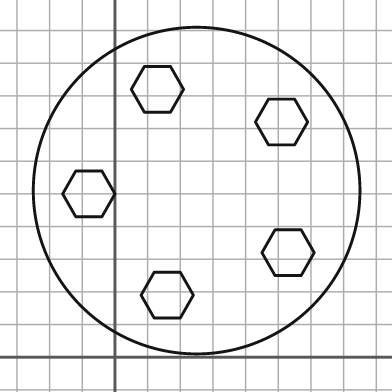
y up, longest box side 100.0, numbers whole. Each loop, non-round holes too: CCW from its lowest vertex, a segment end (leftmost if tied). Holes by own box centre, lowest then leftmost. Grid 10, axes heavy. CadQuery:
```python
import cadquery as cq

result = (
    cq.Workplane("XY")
    .moveTo(25.0, 51.0)
    .circle(50.0)
    .moveTo(12.0, 12.0)
    .lineTo(20.0, 12.0)
    .lineTo(24.0, 19.0)
    .lineTo(20.0, 26.0)
    .lineTo(12.0, 26.0)
    .lineTo(8.0, 19.0)
    .close()
    .moveTo(49.0, 25.0)
    .lineTo(57.0, 25.0)
    .lineTo(61.0, 32.0)
    .lineTo(57.0, 39.0)
    .lineTo(49.0, 39.0)
    .lineTo(45.0, 32.0)
    .close()
    .moveTo(-12.0, 43.0)
    .lineTo(-4.0, 43.0)
    .lineTo(0.0, 50.0)
    .lineTo(-4.0, 57.0)
    .lineTo(-12.0, 57.0)
    .lineTo(-16.0, 50.0)
    .close()
    .moveTo(47.0, 65.0)
    .lineTo(55.0, 65.0)
    .lineTo(59.0, 72.0)
    .lineTo(55.0, 79.0)
    .lineTo(47.0, 79.0)
    .lineTo(43.0, 72.0)
    .close()
    .moveTo(9.0, 75.0)
    .lineTo(17.0, 75.0)
    .lineTo(21.0, 82.0)
    .lineTo(17.0, 89.0)
    .lineTo(9.0, 89.0)
    .lineTo(5.0, 82.0)
    .close()
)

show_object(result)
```